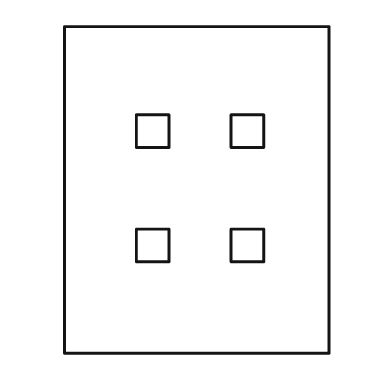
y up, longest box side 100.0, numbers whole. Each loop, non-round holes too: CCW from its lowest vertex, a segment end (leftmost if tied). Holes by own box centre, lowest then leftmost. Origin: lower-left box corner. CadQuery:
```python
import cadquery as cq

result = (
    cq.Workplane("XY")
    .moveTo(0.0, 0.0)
    .lineTo(81.0, 0.0)
    .lineTo(81.0, 100.0)
    .lineTo(0.0, 100.0)
    .close()
    .moveTo(22.0, 28.0)
    .lineTo(32.0, 28.0)
    .lineTo(32.0, 38.0)
    .lineTo(22.0, 38.0)
    .close()
    .moveTo(51.0, 28.0)
    .lineTo(61.0, 28.0)
    .lineTo(61.0, 38.0)
    .lineTo(51.0, 38.0)
    .close()
    .moveTo(22.0, 63.0)
    .lineTo(32.0, 63.0)
    .lineTo(32.0, 73.0)
    .lineTo(22.0, 73.0)
    .close()
    .moveTo(51.0, 63.0)
    .lineTo(61.0, 63.0)
    .lineTo(61.0, 73.0)
    .lineTo(51.0, 73.0)
    .close()
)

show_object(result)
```